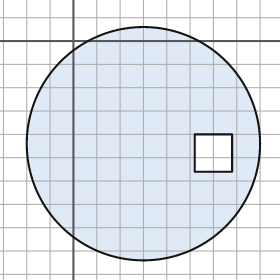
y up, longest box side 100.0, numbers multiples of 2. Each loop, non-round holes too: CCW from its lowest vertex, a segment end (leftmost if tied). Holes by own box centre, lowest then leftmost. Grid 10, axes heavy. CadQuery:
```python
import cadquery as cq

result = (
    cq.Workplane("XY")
    .moveTo(30.0, -44.0)
    .circle(50.0)
    .moveTo(52.0, -56.0)
    .lineTo(68.0, -56.0)
    .lineTo(68.0, -40.0)
    .lineTo(52.0, -40.0)
    .close()
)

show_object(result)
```